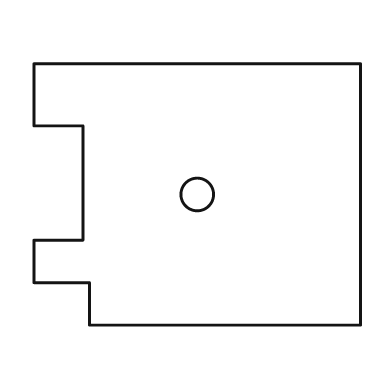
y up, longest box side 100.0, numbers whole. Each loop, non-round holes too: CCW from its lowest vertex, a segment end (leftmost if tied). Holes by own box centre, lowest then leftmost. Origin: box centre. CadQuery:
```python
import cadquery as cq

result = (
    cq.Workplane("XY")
    .moveTo(-33.0, -40.0)
    .lineTo(50.0, -40.0)
    .lineTo(50.0, 40.0)
    .lineTo(-50.0, 40.0)
    .lineTo(-50.0, 21.0)
    .lineTo(-35.0, 21.0)
    .lineTo(-35.0, -14.0)
    .lineTo(-50.0, -14.0)
    .lineTo(-50.0, -27.0)
    .lineTo(-33.0, -27.0)
    .close()
    .moveTo(0.0, 0.0)
    .circle(5.0)
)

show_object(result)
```